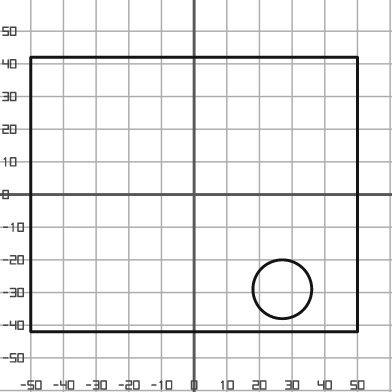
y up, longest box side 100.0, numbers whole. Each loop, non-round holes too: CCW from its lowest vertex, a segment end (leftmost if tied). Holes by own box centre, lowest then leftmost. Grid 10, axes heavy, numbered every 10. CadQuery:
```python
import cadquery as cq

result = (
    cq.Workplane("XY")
    .moveTo(-50.0, -42.0)
    .lineTo(50.0, -42.0)
    .lineTo(50.0, 42.0)
    .lineTo(-50.0, 42.0)
    .close()
    .moveTo(27.0, -29.0)
    .circle(9.0)
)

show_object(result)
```